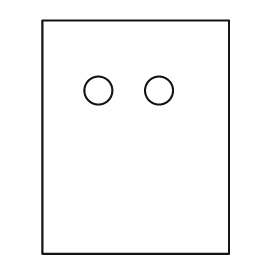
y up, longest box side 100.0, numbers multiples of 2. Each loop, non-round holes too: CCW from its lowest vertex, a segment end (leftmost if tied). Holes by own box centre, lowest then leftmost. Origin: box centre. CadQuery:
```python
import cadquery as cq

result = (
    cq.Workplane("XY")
    .moveTo(-40.0, -50.0)
    .lineTo(40.0, -50.0)
    .lineTo(40.0, 50.0)
    .lineTo(-40.0, 50.0)
    .close()
    .moveTo(-16.0, 20.0)
    .circle(6.0)
    .moveTo(10.0, 20.0)
    .circle(6.0)
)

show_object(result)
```